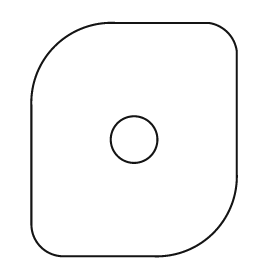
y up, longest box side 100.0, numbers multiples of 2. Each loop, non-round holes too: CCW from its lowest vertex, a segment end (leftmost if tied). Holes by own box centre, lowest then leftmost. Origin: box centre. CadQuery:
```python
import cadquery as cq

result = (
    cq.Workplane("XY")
    .moveTo(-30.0, -50.0)
    .lineTo(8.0, -50.0)
    .threePointArc((34.0, -40.0), (44.0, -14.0))
    .lineTo(44.0, 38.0)
    .threePointArc((40.0, 46.0), (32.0, 50.0))
    .lineTo(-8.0, 50.0)
    .threePointArc((-34.0, 40.0), (-44.0, 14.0))
    .lineTo(-44.0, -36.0)
    .threePointArc((-40.0, -46.0), (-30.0, -50.0))
    .close()
    .moveTo(0.0, 0.0)
    .circle(10.0)
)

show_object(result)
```